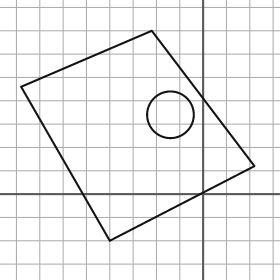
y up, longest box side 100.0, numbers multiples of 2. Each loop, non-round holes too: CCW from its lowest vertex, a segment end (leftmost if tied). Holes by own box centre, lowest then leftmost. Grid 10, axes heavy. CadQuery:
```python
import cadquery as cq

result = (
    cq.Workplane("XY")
    .moveTo(-40.0, -20.0)
    .lineTo(22.0, 12.0)
    .lineTo(-22.0, 70.0)
    .lineTo(-78.0, 46.0)
    .close()
    .moveTo(-14.0, 34.0)
    .circle(10.0)
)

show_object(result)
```